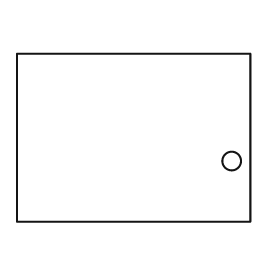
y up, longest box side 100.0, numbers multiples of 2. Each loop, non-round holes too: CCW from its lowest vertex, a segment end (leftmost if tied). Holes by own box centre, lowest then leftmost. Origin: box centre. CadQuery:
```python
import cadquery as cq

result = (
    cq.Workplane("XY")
    .moveTo(-50.0, -36.0)
    .lineTo(50.0, -36.0)
    .lineTo(50.0, 36.0)
    .lineTo(-50.0, 36.0)
    .close()
    .moveTo(42.0, -10.0)
    .circle(4.0)
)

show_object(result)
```